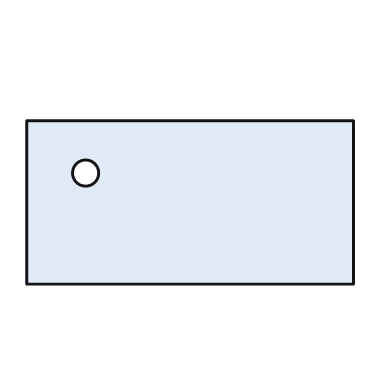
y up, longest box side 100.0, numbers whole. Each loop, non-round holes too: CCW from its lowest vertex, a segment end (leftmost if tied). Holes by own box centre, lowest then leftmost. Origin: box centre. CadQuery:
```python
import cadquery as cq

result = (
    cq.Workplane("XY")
    .moveTo(-50.0, -25.0)
    .lineTo(50.0, -25.0)
    .lineTo(50.0, 25.0)
    .lineTo(-50.0, 25.0)
    .close()
    .moveTo(-32.0, 9.0)
    .circle(4.0)
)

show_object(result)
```